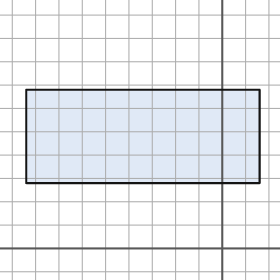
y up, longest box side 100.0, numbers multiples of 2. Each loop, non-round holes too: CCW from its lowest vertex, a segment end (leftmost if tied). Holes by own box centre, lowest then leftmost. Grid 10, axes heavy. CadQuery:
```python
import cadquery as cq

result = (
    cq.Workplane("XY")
    .moveTo(-84.0, 28.0)
    .lineTo(16.0, 28.0)
    .lineTo(16.0, 68.0)
    .lineTo(-84.0, 68.0)
    .close()
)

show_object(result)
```